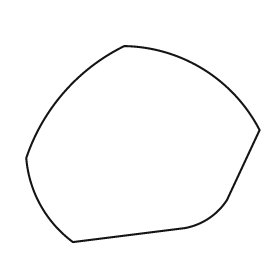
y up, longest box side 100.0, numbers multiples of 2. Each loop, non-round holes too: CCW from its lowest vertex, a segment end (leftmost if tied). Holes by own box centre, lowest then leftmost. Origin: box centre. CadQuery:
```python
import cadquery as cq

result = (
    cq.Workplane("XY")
    .moveTo(-30.0, -42.0)
    .lineTo(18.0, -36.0)
    .threePointArc((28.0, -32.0), (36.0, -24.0))
    .lineTo(50.0, 6.0)
    .threePointArc((26.0, 32.0), (-8.0, 42.0))
    .threePointArc((-34.0, 22.0), (-50.0, -6.0))
    .threePointArc((-44.0, -26.0), (-30.0, -42.0))
    .close()
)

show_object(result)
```